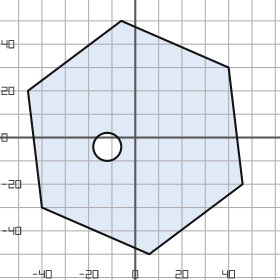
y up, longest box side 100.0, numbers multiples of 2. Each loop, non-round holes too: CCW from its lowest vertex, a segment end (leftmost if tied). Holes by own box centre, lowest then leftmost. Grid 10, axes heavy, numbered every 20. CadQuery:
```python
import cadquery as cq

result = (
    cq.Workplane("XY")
    .moveTo(6.0, -50.0)
    .lineTo(46.0, -20.0)
    .lineTo(40.0, 30.0)
    .lineTo(-6.0, 50.0)
    .lineTo(-46.0, 20.0)
    .lineTo(-40.0, -30.0)
    .close()
    .moveTo(-12.0, -4.0)
    .circle(6.0)
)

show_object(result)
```